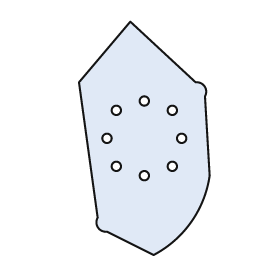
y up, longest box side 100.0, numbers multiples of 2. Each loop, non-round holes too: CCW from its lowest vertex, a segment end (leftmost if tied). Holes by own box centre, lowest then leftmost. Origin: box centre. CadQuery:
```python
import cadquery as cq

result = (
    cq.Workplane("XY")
    .moveTo(4.0, -50.0)
    .threePointArc((20.0, -36.0), (28.0, -16.0))
    .lineTo(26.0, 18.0)
    .threePointArc((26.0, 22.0), (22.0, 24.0))
    .lineTo(-6.0, 50.0)
    .lineTo(-28.0, 24.0)
    .lineTo(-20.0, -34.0)
    .threePointArc((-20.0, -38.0), (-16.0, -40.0))
    .close()
    .moveTo(0.0, -16.0)
    .circle(2.0)
    .moveTo(-12.0, -12.0)
    .circle(2.0)
    .moveTo(12.0, -12.0)
    .circle(2.0)
    .moveTo(-16.0, 0.0)
    .circle(2.0)
    .moveTo(16.0, 0.0)
    .circle(2.0)
    .moveTo(-12.0, 12.0)
    .circle(2.0)
    .moveTo(12.0, 12.0)
    .circle(2.0)
    .moveTo(0.0, 16.0)
    .circle(2.0)
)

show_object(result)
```